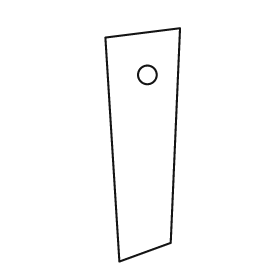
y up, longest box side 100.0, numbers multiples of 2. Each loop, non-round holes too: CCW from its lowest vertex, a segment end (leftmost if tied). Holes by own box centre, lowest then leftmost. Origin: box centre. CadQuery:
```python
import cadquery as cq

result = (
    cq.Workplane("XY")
    .moveTo(-10.0, -50.0)
    .lineTo(12.0, -42.0)
    .lineTo(16.0, 50.0)
    .lineTo(-16.0, 46.0)
    .close()
    .moveTo(2.0, 30.0)
    .circle(4.0)
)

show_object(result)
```